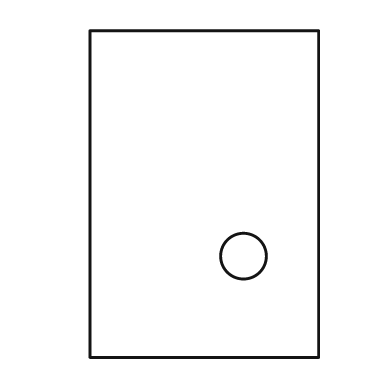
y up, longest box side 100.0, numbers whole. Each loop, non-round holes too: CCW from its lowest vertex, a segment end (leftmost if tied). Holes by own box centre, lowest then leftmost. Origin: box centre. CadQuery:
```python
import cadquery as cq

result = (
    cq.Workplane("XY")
    .moveTo(-35.0, -50.0)
    .lineTo(35.0, -50.0)
    .lineTo(35.0, 50.0)
    .lineTo(-35.0, 50.0)
    .close()
    .moveTo(12.0, -19.0)
    .circle(7.0)
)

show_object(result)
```